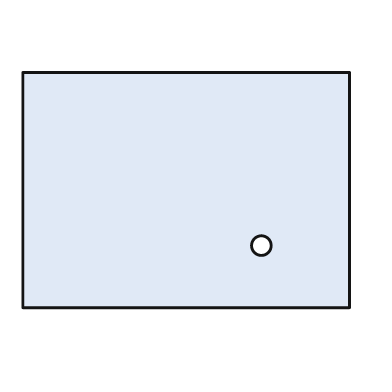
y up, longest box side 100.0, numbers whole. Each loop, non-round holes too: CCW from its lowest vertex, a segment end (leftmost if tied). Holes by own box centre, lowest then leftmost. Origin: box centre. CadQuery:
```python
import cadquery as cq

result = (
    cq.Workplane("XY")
    .moveTo(-50.0, -36.0)
    .lineTo(50.0, -36.0)
    .lineTo(50.0, 36.0)
    .lineTo(-50.0, 36.0)
    .close()
    .moveTo(23.0, -17.0)
    .circle(3.0)
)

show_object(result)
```